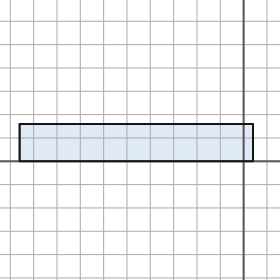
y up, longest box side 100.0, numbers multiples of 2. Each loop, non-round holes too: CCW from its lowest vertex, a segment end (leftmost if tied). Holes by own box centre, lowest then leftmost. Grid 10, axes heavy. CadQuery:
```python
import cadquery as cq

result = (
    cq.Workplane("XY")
    .moveTo(-96.0, 0.0)
    .lineTo(4.0, 0.0)
    .lineTo(4.0, 16.0)
    .lineTo(-96.0, 16.0)
    .close()
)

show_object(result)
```